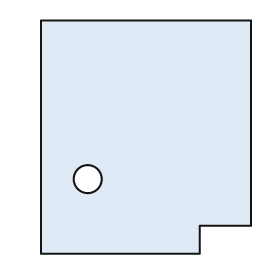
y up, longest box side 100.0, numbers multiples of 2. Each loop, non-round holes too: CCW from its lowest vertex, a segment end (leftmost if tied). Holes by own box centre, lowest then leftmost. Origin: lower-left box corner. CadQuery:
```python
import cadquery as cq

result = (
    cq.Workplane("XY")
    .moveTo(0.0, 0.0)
    .lineTo(68.0, 0.0)
    .lineTo(68.0, 12.0)
    .lineTo(90.0, 12.0)
    .lineTo(90.0, 100.0)
    .lineTo(0.0, 100.0)
    .close()
    .moveTo(20.0, 32.0)
    .circle(6.0)
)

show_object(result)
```